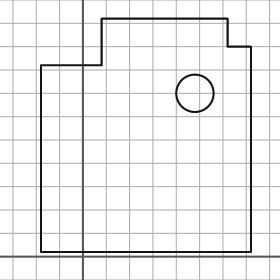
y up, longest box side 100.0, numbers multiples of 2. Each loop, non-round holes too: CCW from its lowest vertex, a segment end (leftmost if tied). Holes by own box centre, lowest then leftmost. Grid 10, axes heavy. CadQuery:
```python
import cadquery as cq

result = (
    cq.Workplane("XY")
    .moveTo(-18.0, 2.0)
    .lineTo(72.0, 2.0)
    .lineTo(72.0, 90.0)
    .lineTo(62.0, 90.0)
    .lineTo(62.0, 102.0)
    .lineTo(8.0, 102.0)
    .lineTo(8.0, 82.0)
    .lineTo(-18.0, 82.0)
    .close()
    .moveTo(48.0, 70.0)
    .circle(8.0)
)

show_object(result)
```